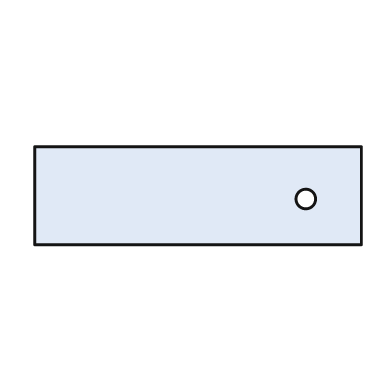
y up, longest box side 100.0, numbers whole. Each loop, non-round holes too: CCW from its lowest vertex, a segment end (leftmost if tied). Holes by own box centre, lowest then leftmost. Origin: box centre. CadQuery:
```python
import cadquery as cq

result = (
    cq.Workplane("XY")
    .moveTo(-50.0, -15.0)
    .lineTo(50.0, -15.0)
    .lineTo(50.0, 15.0)
    .lineTo(-50.0, 15.0)
    .close()
    .moveTo(33.0, -1.0)
    .circle(3.0)
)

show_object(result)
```